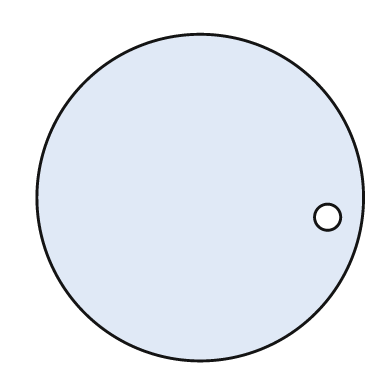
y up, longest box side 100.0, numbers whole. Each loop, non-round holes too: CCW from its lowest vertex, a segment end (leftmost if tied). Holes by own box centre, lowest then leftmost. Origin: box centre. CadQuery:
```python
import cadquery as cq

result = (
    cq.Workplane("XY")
    .moveTo(0.0, 0.0)
    .circle(50.0)
    .moveTo(39.0, -6.0)
    .circle(4.0)
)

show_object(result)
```